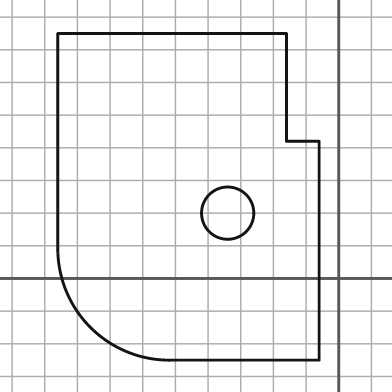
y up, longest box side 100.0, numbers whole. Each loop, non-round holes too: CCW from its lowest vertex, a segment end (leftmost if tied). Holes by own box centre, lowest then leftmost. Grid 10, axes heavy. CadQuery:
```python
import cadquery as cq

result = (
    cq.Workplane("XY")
    .moveTo(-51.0, -25.0)
    .lineTo(-6.0, -25.0)
    .lineTo(-6.0, 42.0)
    .lineTo(-16.0, 42.0)
    .lineTo(-16.0, 75.0)
    .lineTo(-86.0, 75.0)
    .lineTo(-86.0, 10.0)
    .threePointArc((-76.0, -15.0), (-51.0, -25.0))
    .close()
    .moveTo(-34.0, 20.0)
    .circle(8.0)
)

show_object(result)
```